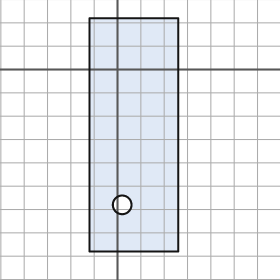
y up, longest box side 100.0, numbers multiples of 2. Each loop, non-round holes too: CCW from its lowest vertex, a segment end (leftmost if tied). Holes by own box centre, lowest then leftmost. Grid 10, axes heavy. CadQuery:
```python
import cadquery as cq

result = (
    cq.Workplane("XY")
    .moveTo(-12.0, -78.0)
    .lineTo(26.0, -78.0)
    .lineTo(26.0, 22.0)
    .lineTo(-12.0, 22.0)
    .close()
    .moveTo(2.0, -58.0)
    .circle(4.0)
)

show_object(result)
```